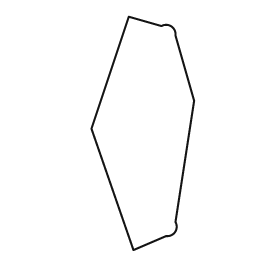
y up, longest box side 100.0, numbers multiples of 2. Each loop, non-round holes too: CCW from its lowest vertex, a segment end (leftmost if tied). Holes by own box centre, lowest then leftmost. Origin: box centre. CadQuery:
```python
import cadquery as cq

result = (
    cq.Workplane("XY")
    .moveTo(-4.0, -50.0)
    .lineTo(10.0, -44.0)
    .threePointArc((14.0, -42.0), (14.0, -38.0))
    .lineTo(22.0, 14.0)
    .lineTo(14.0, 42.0)
    .threePointArc((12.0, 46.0), (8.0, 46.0))
    .lineTo(-6.0, 50.0)
    .lineTo(-22.0, 2.0)
    .close()
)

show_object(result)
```